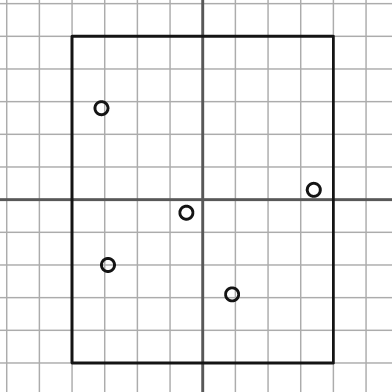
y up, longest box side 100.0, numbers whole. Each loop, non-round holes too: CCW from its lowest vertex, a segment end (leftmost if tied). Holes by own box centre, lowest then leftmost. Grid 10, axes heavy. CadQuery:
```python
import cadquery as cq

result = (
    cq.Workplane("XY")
    .moveTo(-40.0, -50.0)
    .lineTo(40.0, -50.0)
    .lineTo(40.0, 50.0)
    .lineTo(-40.0, 50.0)
    .close()
    .moveTo(9.0, -29.0)
    .circle(2.0)
    .moveTo(-29.0, -20.0)
    .circle(2.0)
    .moveTo(-5.0, -4.0)
    .circle(2.0)
    .moveTo(34.0, 3.0)
    .circle(2.0)
    .moveTo(-31.0, 28.0)
    .circle(2.0)
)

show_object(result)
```